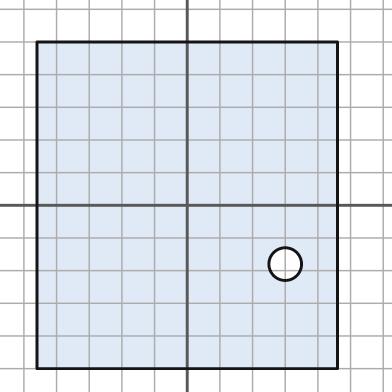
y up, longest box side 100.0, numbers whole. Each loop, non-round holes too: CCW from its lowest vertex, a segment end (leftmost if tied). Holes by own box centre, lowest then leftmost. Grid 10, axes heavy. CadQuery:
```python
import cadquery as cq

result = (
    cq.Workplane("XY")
    .moveTo(-46.0, -50.0)
    .lineTo(46.0, -50.0)
    .lineTo(46.0, 50.0)
    .lineTo(-46.0, 50.0)
    .close()
    .moveTo(30.0, -18.0)
    .circle(5.0)
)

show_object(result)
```